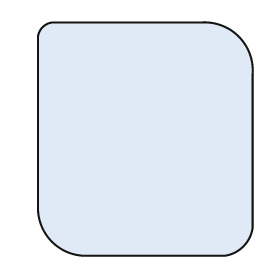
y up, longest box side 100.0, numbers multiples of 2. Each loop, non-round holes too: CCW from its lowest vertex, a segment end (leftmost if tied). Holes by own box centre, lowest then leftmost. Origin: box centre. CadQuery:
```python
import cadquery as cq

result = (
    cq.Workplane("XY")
    .moveTo(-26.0, -50.0)
    .lineTo(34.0, -50.0)
    .threePointArc((42.0, -46.0), (46.0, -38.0))
    .lineTo(46.0, 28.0)
    .threePointArc((40.0, 44.0), (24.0, 50.0))
    .lineTo(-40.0, 50.0)
    .threePointArc((-44.0, 48.0), (-46.0, 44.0))
    .lineTo(-46.0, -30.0)
    .threePointArc((-40.0, -44.0), (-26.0, -50.0))
    .close()
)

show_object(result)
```